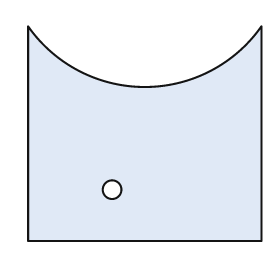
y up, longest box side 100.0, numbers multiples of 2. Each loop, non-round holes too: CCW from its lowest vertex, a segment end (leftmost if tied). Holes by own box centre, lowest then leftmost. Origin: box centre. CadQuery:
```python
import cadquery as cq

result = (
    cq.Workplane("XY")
    .moveTo(-50.0, -46.0)
    .lineTo(50.0, -46.0)
    .lineTo(50.0, 46.0)
    .threePointArc((0.0, 20.0), (-50.0, 46.0))
    .close()
    .moveTo(-14.0, -24.0)
    .circle(4.0)
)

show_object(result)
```